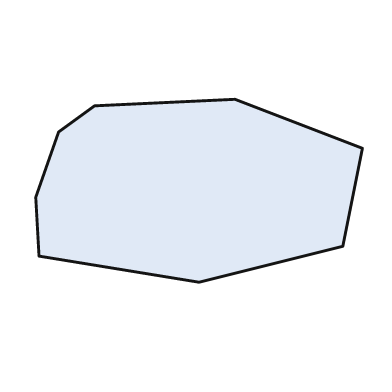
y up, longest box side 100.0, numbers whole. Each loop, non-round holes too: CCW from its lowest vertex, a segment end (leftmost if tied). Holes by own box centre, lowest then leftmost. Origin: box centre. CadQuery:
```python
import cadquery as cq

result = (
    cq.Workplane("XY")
    .moveTo(0.0, -28.0)
    .lineTo(44.0, -17.0)
    .lineTo(50.0, 13.0)
    .lineTo(11.0, 28.0)
    .lineTo(-32.0, 26.0)
    .lineTo(-43.0, 18.0)
    .lineTo(-50.0, -2.0)
    .lineTo(-49.0, -20.0)
    .close()
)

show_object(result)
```